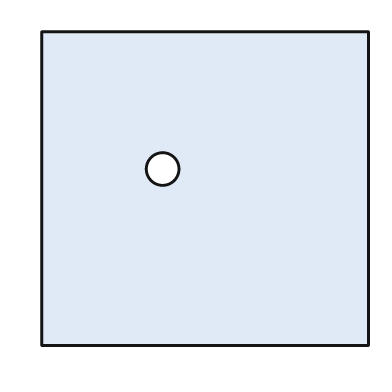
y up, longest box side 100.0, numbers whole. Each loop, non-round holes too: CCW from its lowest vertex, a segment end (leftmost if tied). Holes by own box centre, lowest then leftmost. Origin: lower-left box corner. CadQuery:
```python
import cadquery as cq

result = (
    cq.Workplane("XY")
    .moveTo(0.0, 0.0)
    .lineTo(100.0, 0.0)
    .lineTo(100.0, 96.0)
    .lineTo(0.0, 96.0)
    .close()
    .moveTo(37.0, 54.0)
    .circle(5.0)
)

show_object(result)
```